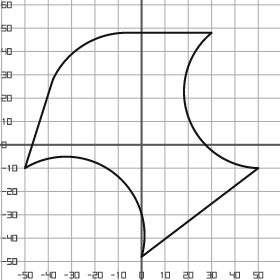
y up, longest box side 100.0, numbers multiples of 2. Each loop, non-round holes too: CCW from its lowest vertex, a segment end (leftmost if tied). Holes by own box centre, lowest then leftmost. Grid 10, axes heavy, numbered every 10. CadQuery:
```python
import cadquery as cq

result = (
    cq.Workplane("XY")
    .moveTo(0.0, -48.0)
    .lineTo(50.0, -10.0)
    .threePointArc((20.0, 12.0), (30.0, 48.0))
    .lineTo(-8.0, 48.0)
    .threePointArc((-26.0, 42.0), (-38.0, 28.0))
    .lineTo(-50.0, -10.0)
    .threePointArc((-12.0, -12.0), (0.0, -48.0))
    .close()
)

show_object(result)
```